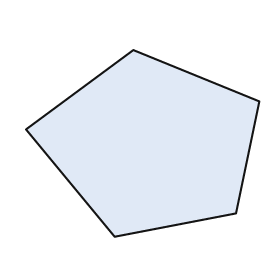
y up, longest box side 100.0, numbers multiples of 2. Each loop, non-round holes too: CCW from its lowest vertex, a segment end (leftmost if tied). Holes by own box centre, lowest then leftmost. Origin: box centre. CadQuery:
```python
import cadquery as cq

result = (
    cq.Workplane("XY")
    .moveTo(-12.0, -40.0)
    .lineTo(40.0, -30.0)
    .lineTo(50.0, 18.0)
    .lineTo(-4.0, 40.0)
    .lineTo(-50.0, 6.0)
    .close()
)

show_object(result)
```